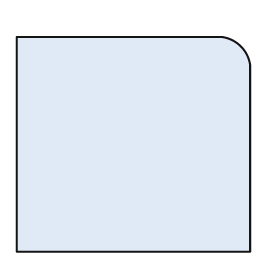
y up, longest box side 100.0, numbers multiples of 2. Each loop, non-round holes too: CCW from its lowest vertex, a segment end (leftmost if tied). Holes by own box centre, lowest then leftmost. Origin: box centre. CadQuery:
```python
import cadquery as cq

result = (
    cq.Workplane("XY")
    .moveTo(-50.0, -46.0)
    .lineTo(50.0, -46.0)
    .lineTo(50.0, 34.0)
    .threePointArc((46.0, 42.0), (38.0, 46.0))
    .lineTo(-50.0, 46.0)
    .close()
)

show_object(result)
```